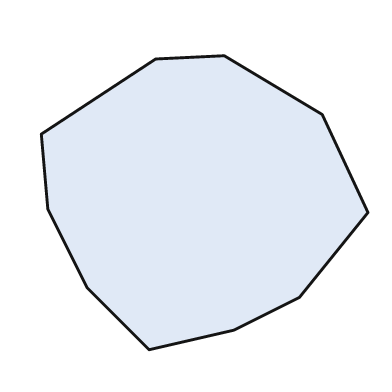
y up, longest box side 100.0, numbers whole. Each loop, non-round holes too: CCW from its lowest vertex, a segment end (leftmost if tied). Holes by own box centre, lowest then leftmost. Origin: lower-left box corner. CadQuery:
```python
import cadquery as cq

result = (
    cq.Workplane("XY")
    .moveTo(33.0, 0.0)
    .lineTo(59.0, 6.0)
    .lineTo(79.0, 16.0)
    .lineTo(100.0, 42.0)
    .lineTo(86.0, 72.0)
    .lineTo(56.0, 90.0)
    .lineTo(35.0, 89.0)
    .lineTo(0.0, 66.0)
    .lineTo(2.0, 43.0)
    .lineTo(14.0, 19.0)
    .close()
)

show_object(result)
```